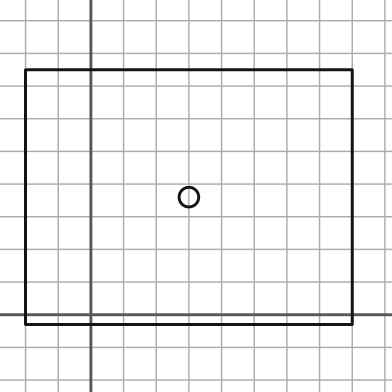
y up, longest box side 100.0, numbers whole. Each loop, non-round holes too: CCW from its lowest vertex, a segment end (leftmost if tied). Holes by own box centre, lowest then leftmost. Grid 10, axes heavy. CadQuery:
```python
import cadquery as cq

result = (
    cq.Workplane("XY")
    .moveTo(-20.0, -3.0)
    .lineTo(80.0, -3.0)
    .lineTo(80.0, 75.0)
    .lineTo(-20.0, 75.0)
    .close()
    .moveTo(30.0, 36.0)
    .circle(3.0)
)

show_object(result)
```